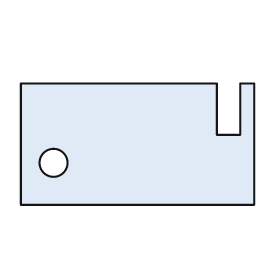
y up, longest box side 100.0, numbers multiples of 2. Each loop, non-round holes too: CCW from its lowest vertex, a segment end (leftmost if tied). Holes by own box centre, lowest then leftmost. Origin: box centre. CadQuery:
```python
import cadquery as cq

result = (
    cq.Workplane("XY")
    .moveTo(-50.0, -26.0)
    .lineTo(50.0, -26.0)
    .lineTo(50.0, 26.0)
    .lineTo(44.0, 26.0)
    .lineTo(44.0, 4.0)
    .lineTo(34.0, 4.0)
    .lineTo(34.0, 26.0)
    .lineTo(-50.0, 26.0)
    .close()
    .moveTo(-36.0, -8.0)
    .circle(6.0)
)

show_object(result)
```